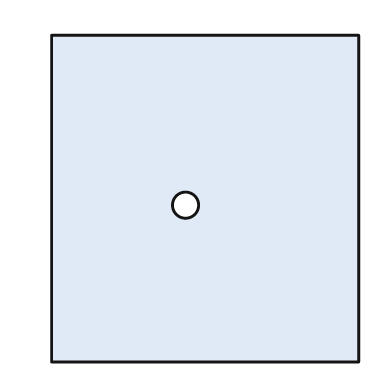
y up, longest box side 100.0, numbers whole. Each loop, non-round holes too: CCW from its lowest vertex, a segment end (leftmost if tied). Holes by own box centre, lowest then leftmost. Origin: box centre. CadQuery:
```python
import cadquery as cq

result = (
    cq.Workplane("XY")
    .moveTo(-47.0, -50.0)
    .lineTo(47.0, -50.0)
    .lineTo(47.0, 50.0)
    .lineTo(-47.0, 50.0)
    .close()
    .moveTo(-6.0, -2.0)
    .circle(4.0)
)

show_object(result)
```